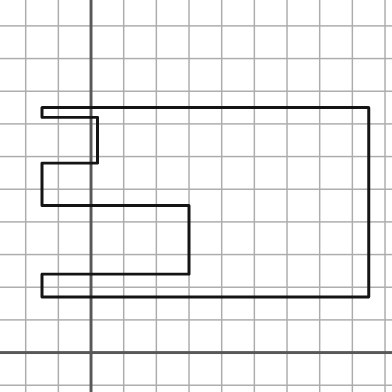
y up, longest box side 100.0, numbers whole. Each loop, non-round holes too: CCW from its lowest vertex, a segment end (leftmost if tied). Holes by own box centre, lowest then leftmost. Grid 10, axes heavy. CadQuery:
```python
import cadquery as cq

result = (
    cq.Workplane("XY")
    .moveTo(-15.0, 17.0)
    .lineTo(85.0, 17.0)
    .lineTo(85.0, 75.0)
    .lineTo(-15.0, 75.0)
    .lineTo(-15.0, 72.0)
    .lineTo(2.0, 72.0)
    .lineTo(2.0, 58.0)
    .lineTo(-15.0, 58.0)
    .lineTo(-15.0, 45.0)
    .lineTo(30.0, 45.0)
    .lineTo(30.0, 24.0)
    .lineTo(-15.0, 24.0)
    .close()
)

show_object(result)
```